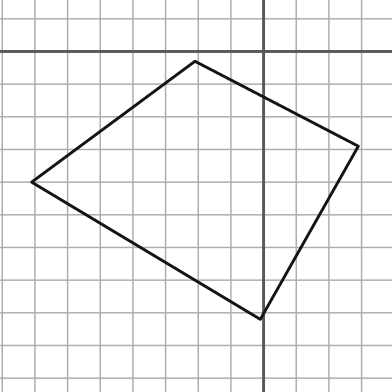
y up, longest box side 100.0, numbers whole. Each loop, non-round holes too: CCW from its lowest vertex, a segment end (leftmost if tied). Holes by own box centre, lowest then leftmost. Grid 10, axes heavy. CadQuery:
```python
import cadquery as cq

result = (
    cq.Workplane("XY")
    .moveTo(-1.0, -82.0)
    .lineTo(29.0, -29.0)
    .lineTo(-21.0, -3.0)
    .lineTo(-71.0, -40.0)
    .close()
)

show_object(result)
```